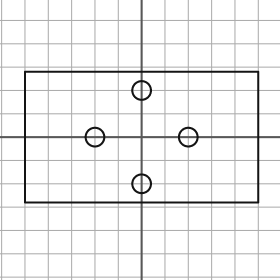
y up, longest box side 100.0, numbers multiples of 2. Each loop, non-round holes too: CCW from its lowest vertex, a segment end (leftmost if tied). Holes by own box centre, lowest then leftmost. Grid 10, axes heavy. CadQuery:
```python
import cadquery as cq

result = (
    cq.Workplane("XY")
    .moveTo(-50.0, -28.0)
    .lineTo(50.0, -28.0)
    .lineTo(50.0, 28.0)
    .lineTo(-50.0, 28.0)
    .close()
    .moveTo(0.0, -20.0)
    .circle(4.0)
    .moveTo(-20.0, 0.0)
    .circle(4.0)
    .moveTo(20.0, 0.0)
    .circle(4.0)
    .moveTo(0.0, 20.0)
    .circle(4.0)
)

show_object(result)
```